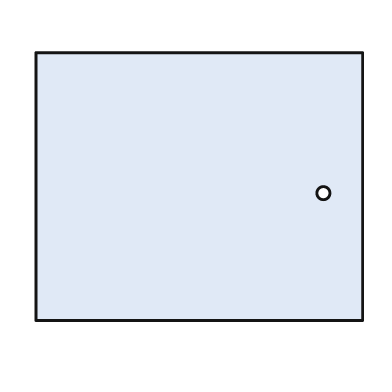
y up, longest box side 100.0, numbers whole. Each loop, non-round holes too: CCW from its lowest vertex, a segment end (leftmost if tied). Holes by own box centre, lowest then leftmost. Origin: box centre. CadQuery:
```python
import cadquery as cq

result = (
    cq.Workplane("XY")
    .moveTo(-50.0, -41.0)
    .lineTo(50.0, -41.0)
    .lineTo(50.0, 41.0)
    .lineTo(-50.0, 41.0)
    .close()
    .moveTo(38.0, -2.0)
    .circle(2.0)
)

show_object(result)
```